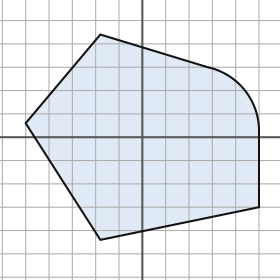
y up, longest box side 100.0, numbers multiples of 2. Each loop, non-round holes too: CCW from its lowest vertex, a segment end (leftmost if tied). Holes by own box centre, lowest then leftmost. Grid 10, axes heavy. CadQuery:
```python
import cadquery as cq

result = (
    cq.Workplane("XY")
    .moveTo(-18.0, -44.0)
    .lineTo(50.0, -30.0)
    .lineTo(50.0, 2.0)
    .threePointArc((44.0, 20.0), (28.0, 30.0))
    .lineTo(-18.0, 44.0)
    .lineTo(-50.0, 6.0)
    .close()
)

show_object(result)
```